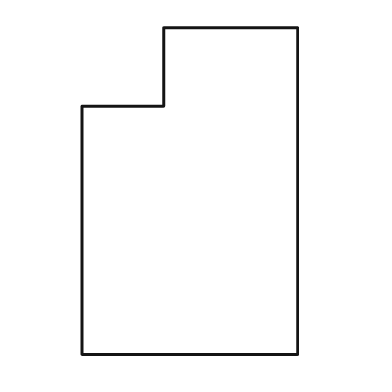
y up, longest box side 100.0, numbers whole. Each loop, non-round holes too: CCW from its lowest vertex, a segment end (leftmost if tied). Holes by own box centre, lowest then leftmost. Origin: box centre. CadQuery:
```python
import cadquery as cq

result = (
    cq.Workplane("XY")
    .moveTo(-33.0, -50.0)
    .lineTo(33.0, -50.0)
    .lineTo(33.0, 50.0)
    .lineTo(-8.0, 50.0)
    .lineTo(-8.0, 26.0)
    .lineTo(-33.0, 26.0)
    .close()
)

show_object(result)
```